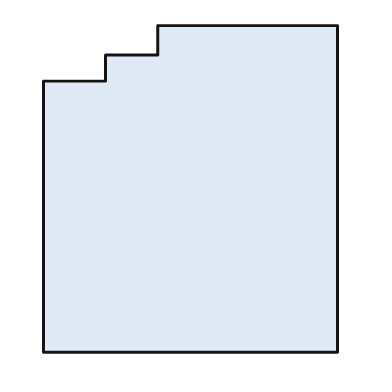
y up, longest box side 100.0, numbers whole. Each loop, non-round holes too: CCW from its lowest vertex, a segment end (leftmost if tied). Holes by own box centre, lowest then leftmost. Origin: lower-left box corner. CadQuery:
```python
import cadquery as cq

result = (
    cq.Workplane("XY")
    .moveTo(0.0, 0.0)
    .lineTo(90.0, 0.0)
    .lineTo(90.0, 100.0)
    .lineTo(35.0, 100.0)
    .lineTo(35.0, 91.0)
    .lineTo(19.0, 91.0)
    .lineTo(19.0, 83.0)
    .lineTo(0.0, 83.0)
    .close()
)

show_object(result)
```